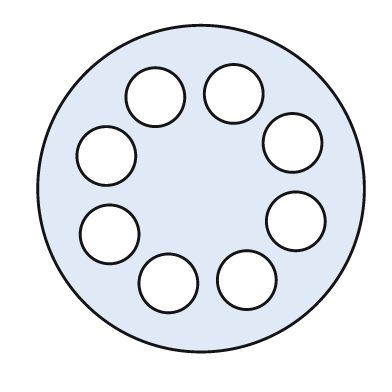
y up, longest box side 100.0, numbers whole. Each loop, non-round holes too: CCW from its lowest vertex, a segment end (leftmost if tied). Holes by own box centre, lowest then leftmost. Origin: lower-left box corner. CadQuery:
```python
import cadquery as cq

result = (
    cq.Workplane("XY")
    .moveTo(50.0, 50.0)
    .circle(50.0)
    .moveTo(40.0, 21.0)
    .circle(9.0)
    .moveTo(64.0, 22.0)
    .circle(9.0)
    .moveTo(22.0, 36.0)
    .circle(9.0)
    .moveTo(79.0, 40.0)
    .circle(9.0)
    .moveTo(21.0, 60.0)
    .circle(9.0)
    .moveTo(78.0, 64.0)
    .circle(9.0)
    .moveTo(36.0, 78.0)
    .circle(9.0)
    .moveTo(60.0, 79.0)
    .circle(9.0)
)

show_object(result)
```